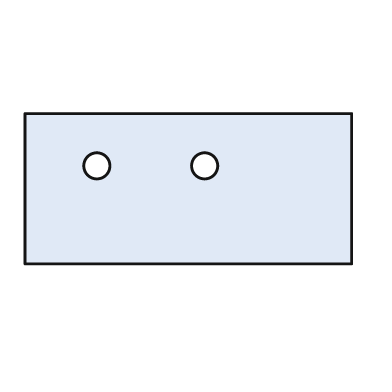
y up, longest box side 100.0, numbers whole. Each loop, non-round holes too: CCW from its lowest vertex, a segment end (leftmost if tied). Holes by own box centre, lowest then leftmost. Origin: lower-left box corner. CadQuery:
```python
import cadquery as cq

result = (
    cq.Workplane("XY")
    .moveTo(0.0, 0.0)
    .lineTo(100.0, 0.0)
    .lineTo(100.0, 46.0)
    .lineTo(0.0, 46.0)
    .close()
    .moveTo(22.0, 30.0)
    .circle(4.0)
    .moveTo(55.0, 30.0)
    .circle(4.0)
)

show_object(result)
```